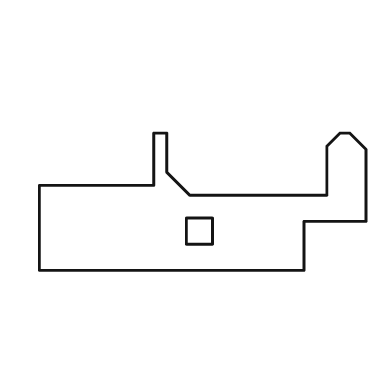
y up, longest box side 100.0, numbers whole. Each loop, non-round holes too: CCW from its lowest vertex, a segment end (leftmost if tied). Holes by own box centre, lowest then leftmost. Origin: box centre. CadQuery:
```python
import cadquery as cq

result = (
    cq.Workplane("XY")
    .moveTo(-50.0, -21.0)
    .lineTo(31.0, -21.0)
    .lineTo(31.0, -6.0)
    .lineTo(50.0, -6.0)
    .lineTo(50.0, 16.0)
    .lineTo(45.0, 21.0)
    .lineTo(42.0, 21.0)
    .lineTo(38.0, 17.0)
    .lineTo(38.0, 2.0)
    .lineTo(-4.0, 2.0)
    .lineTo(-11.0, 9.0)
    .lineTo(-11.0, 21.0)
    .lineTo(-15.0, 21.0)
    .lineTo(-15.0, 5.0)
    .lineTo(-50.0, 5.0)
    .close()
    .moveTo(-5.0, -13.0)
    .lineTo(3.0, -13.0)
    .lineTo(3.0, -5.0)
    .lineTo(-5.0, -5.0)
    .close()
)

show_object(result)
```